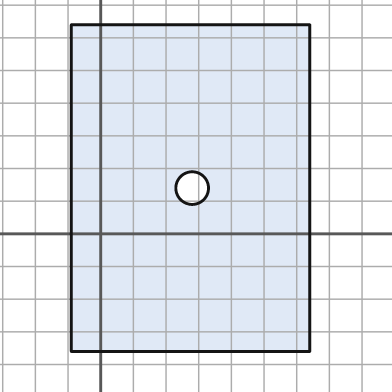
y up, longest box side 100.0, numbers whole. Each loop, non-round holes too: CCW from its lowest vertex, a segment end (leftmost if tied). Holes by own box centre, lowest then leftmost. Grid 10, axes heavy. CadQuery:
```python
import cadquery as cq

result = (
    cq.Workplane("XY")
    .moveTo(-9.0, -36.0)
    .lineTo(64.0, -36.0)
    .lineTo(64.0, 64.0)
    .lineTo(-9.0, 64.0)
    .close()
    .moveTo(28.0, 14.0)
    .circle(5.0)
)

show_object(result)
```